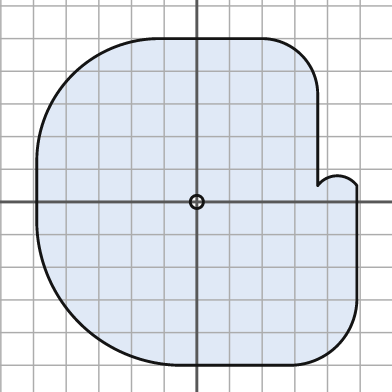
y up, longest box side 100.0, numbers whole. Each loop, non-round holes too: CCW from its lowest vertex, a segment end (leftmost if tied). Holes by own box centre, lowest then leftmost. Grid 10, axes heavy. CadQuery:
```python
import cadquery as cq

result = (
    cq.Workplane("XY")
    .moveTo(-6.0, -50.0)
    .lineTo(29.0, -50.0)
    .threePointArc((43.0, -44.0), (49.0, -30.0))
    .lineTo(49.0, 5.0)
    .threePointArc((43.0, 8.0), (37.0, 5.0))
    .lineTo(37.0, 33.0)
    .threePointArc((32.0, 45.0), (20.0, 50.0))
    .lineTo(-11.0, 50.0)
    .threePointArc((-38.0, 39.0), (-49.0, 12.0))
    .lineTo(-49.0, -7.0)
    .threePointArc((-36.0, -37.0), (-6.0, -50.0))
    .close()
    .moveTo(0.0, 0.0)
    .circle(2.0)
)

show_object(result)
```